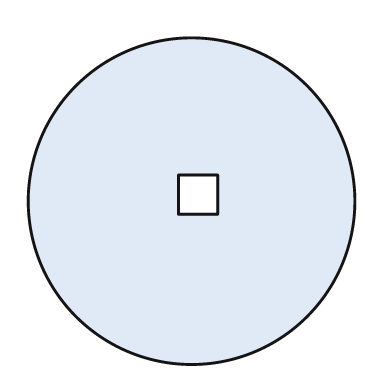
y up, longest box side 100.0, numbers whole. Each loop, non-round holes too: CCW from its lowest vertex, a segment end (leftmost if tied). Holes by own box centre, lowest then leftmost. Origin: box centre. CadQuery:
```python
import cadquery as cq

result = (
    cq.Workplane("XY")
    .moveTo(0.0, 0.0)
    .circle(50.0)
    .moveTo(-4.0, -4.0)
    .lineTo(8.0, -4.0)
    .lineTo(8.0, 8.0)
    .lineTo(-4.0, 8.0)
    .close()
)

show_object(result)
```